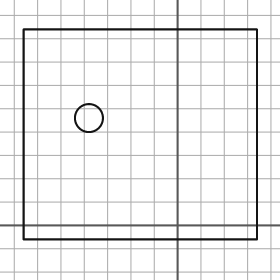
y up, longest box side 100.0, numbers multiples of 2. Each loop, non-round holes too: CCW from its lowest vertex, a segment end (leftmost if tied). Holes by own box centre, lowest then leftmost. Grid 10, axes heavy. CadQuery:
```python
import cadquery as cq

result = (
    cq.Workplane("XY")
    .moveTo(-66.0, -6.0)
    .lineTo(34.0, -6.0)
    .lineTo(34.0, 84.0)
    .lineTo(-66.0, 84.0)
    .close()
    .moveTo(-38.0, 46.0)
    .circle(6.0)
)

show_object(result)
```